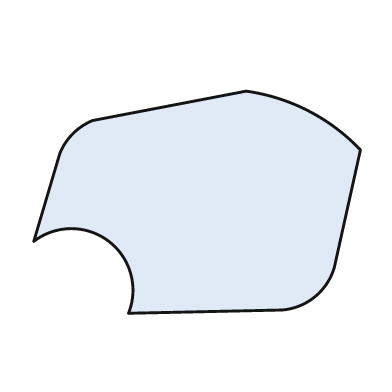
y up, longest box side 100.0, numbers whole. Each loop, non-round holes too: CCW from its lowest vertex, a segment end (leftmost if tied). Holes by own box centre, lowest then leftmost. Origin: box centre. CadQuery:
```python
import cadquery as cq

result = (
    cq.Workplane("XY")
    .moveTo(-21.0, -34.0)
    .lineTo(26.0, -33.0)
    .threePointArc((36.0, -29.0), (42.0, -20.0))
    .lineTo(50.0, 16.0)
    .threePointArc((34.0, 28.0), (15.0, 34.0))
    .lineTo(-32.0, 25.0)
    .threePointArc((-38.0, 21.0), (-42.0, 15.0))
    .lineTo(-50.0, -12.0)
    .threePointArc((-27.0, -12.0), (-21.0, -34.0))
    .close()
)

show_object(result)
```